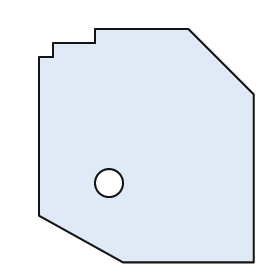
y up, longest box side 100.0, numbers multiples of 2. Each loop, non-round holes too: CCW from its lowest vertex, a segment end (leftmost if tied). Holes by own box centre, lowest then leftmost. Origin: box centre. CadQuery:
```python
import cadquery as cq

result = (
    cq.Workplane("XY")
    .moveTo(-10.0, -50.0)
    .lineTo(46.0, -50.0)
    .lineTo(46.0, 22.0)
    .lineTo(18.0, 50.0)
    .lineTo(-22.0, 50.0)
    .lineTo(-22.0, 44.0)
    .lineTo(-40.0, 44.0)
    .lineTo(-40.0, 38.0)
    .lineTo(-46.0, 38.0)
    .lineTo(-46.0, -30.0)
    .close()
    .moveTo(-16.0, -16.0)
    .circle(6.0)
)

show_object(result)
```